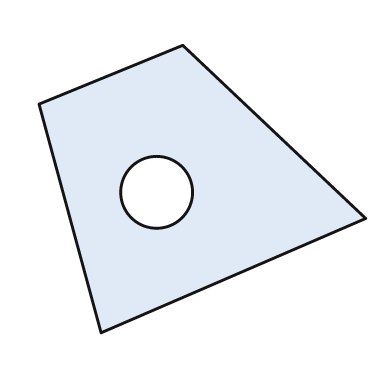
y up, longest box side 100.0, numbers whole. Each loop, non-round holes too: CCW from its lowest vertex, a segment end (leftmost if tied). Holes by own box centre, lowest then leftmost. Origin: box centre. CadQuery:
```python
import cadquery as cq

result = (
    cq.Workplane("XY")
    .moveTo(-31.0, -44.0)
    .lineTo(50.0, -9.0)
    .lineTo(-6.0, 44.0)
    .lineTo(-50.0, 26.0)
    .close()
    .moveTo(-14.0, -1.0)
    .circle(11.0)
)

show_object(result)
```